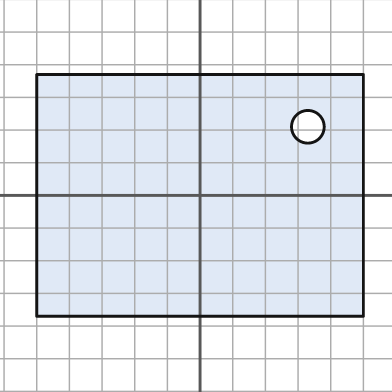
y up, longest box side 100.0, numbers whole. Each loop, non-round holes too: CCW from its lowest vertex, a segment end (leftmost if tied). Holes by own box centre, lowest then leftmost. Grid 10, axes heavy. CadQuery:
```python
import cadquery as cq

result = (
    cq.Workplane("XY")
    .moveTo(-50.0, -37.0)
    .lineTo(50.0, -37.0)
    .lineTo(50.0, 37.0)
    .lineTo(-50.0, 37.0)
    .close()
    .moveTo(33.0, 21.0)
    .circle(5.0)
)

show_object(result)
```